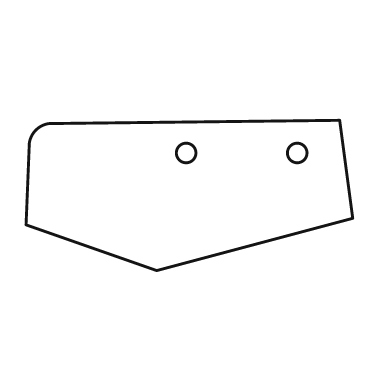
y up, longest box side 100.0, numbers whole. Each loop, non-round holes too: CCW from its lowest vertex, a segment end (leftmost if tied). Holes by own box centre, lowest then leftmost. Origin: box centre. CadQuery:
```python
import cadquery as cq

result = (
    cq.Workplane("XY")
    .moveTo(-10.0, -23.0)
    .lineTo(50.0, -7.0)
    .lineTo(46.0, 23.0)
    .lineTo(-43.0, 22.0)
    .threePointArc((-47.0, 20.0), (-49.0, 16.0))
    .lineTo(-50.0, -9.0)
    .close()
    .moveTo(-1.0, 13.0)
    .circle(3.0)
    .moveTo(33.0, 13.0)
    .circle(3.0)
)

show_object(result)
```